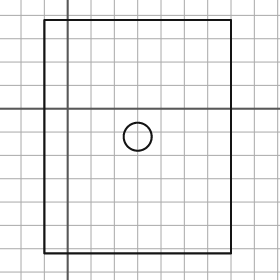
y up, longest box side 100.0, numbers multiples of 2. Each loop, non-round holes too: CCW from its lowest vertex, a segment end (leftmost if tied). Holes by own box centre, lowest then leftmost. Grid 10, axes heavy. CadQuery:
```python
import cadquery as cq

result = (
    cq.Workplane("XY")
    .moveTo(-10.0, -62.0)
    .lineTo(70.0, -62.0)
    .lineTo(70.0, 38.0)
    .lineTo(-10.0, 38.0)
    .close()
    .moveTo(30.0, -12.0)
    .circle(6.0)
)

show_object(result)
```